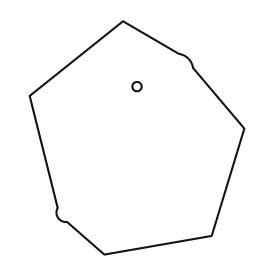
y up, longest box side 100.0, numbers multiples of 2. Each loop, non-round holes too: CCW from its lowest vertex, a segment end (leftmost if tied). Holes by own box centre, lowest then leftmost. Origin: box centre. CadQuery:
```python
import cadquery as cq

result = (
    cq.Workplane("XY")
    .moveTo(-14.0, -50.0)
    .lineTo(32.0, -42.0)
    .lineTo(46.0, 4.0)
    .lineTo(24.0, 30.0)
    .threePointArc((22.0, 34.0), (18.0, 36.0))
    .lineTo(-6.0, 50.0)
    .lineTo(-46.0, 18.0)
    .lineTo(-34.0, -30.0)
    .threePointArc((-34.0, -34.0), (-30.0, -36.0))
    .close()
    .moveTo(0.0, 22.0)
    .circle(2.0)
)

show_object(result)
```